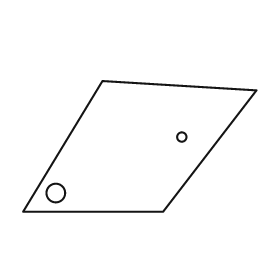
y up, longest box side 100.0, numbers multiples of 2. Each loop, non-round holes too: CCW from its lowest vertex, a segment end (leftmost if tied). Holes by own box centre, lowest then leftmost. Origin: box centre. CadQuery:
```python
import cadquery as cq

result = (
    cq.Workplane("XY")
    .moveTo(-50.0, -28.0)
    .lineTo(10.0, -28.0)
    .lineTo(50.0, 24.0)
    .lineTo(-16.0, 28.0)
    .close()
    .moveTo(-36.0, -20.0)
    .circle(4.0)
    .moveTo(18.0, 4.0)
    .circle(2.0)
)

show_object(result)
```